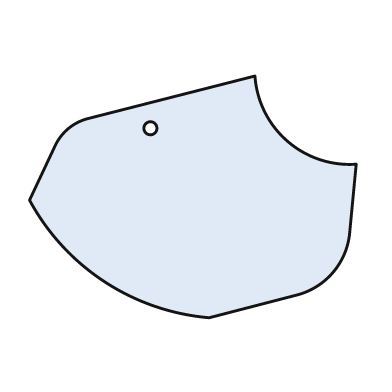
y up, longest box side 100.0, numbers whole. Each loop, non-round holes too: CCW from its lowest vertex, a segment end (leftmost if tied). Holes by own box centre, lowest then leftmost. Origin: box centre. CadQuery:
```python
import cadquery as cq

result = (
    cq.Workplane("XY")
    .moveTo(5.0, -37.0)
    .lineTo(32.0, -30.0)
    .threePointArc((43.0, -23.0), (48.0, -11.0))
    .lineTo(50.0, 10.0)
    .threePointArc((29.0, 17.0), (19.0, 37.0))
    .lineTo(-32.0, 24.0)
    .threePointArc((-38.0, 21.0), (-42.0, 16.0))
    .lineTo(-50.0, -1.0)
    .threePointArc((-27.0, -26.0), (5.0, -37.0))
    .close()
    .moveTo(-13.0, 21.0)
    .circle(2.0)
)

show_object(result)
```